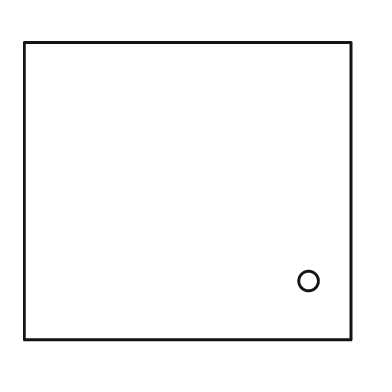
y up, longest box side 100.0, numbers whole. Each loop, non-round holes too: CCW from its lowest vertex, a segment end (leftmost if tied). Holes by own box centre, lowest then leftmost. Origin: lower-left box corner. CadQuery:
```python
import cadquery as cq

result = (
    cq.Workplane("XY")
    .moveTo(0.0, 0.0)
    .lineTo(100.0, 0.0)
    .lineTo(100.0, 91.0)
    .lineTo(0.0, 91.0)
    .close()
    .moveTo(87.0, 18.0)
    .circle(3.0)
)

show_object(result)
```